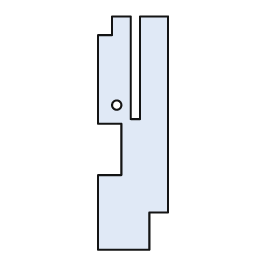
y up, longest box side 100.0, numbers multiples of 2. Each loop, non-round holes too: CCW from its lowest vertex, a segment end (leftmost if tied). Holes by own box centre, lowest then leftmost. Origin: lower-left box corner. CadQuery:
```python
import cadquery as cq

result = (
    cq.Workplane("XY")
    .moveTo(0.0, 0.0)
    .lineTo(22.0, 0.0)
    .lineTo(22.0, 16.0)
    .lineTo(30.0, 16.0)
    .lineTo(30.0, 100.0)
    .lineTo(18.0, 100.0)
    .lineTo(18.0, 56.0)
    .lineTo(14.0, 56.0)
    .lineTo(14.0, 100.0)
    .lineTo(6.0, 100.0)
    .lineTo(6.0, 92.0)
    .lineTo(0.0, 92.0)
    .lineTo(0.0, 54.0)
    .lineTo(10.0, 54.0)
    .lineTo(10.0, 32.0)
    .lineTo(0.0, 32.0)
    .close()
    .moveTo(8.0, 62.0)
    .circle(2.0)
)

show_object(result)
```